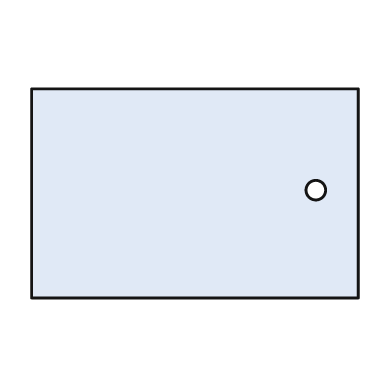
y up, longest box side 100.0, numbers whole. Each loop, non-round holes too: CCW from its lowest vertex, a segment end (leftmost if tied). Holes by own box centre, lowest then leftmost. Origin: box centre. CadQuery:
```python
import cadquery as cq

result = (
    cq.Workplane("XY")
    .moveTo(-50.0, -32.0)
    .lineTo(50.0, -32.0)
    .lineTo(50.0, 32.0)
    .lineTo(-50.0, 32.0)
    .close()
    .moveTo(37.0, 1.0)
    .circle(3.0)
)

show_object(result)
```